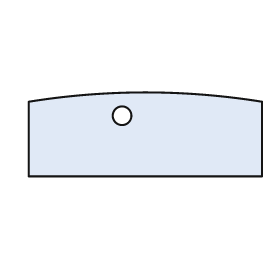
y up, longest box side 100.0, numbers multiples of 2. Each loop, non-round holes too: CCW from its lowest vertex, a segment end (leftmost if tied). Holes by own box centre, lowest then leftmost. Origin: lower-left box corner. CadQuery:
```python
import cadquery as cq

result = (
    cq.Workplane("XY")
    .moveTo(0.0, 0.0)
    .lineTo(100.0, 0.0)
    .lineTo(100.0, 32.0)
    .threePointArc((50.0, 36.0), (0.0, 32.0))
    .close()
    .moveTo(40.0, 26.0)
    .circle(4.0)
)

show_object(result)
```